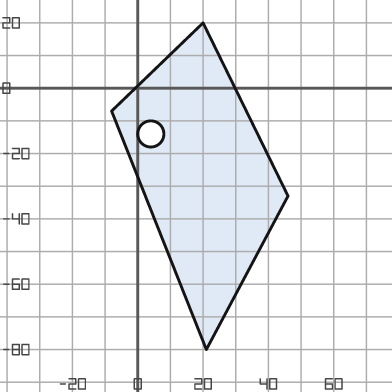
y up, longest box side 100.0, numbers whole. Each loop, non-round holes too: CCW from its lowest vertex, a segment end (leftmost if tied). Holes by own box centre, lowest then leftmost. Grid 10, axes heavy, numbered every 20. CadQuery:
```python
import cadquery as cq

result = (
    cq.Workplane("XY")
    .moveTo(21.0, -80.0)
    .lineTo(46.0, -33.0)
    .lineTo(20.0, 20.0)
    .lineTo(-8.0, -7.0)
    .close()
    .moveTo(4.0, -14.0)
    .circle(4.0)
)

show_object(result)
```